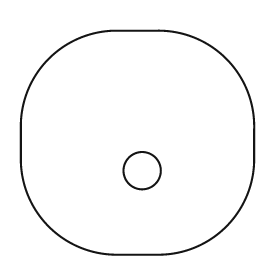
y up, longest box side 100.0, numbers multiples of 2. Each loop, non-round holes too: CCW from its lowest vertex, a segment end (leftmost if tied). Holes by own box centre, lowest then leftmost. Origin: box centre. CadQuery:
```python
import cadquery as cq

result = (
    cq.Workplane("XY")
    .moveTo(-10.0, -48.0)
    .lineTo(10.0, -48.0)
    .threePointArc((38.0, -36.0), (50.0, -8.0))
    .lineTo(50.0, 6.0)
    .threePointArc((38.0, 36.0), (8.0, 48.0))
    .lineTo(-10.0, 48.0)
    .threePointArc((-38.0, 36.0), (-50.0, 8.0))
    .lineTo(-50.0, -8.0)
    .threePointArc((-38.0, -36.0), (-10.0, -48.0))
    .close()
    .moveTo(2.0, -12.0)
    .circle(8.0)
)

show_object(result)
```